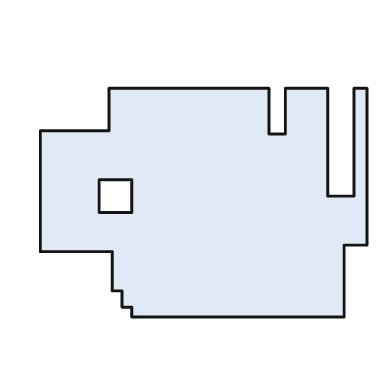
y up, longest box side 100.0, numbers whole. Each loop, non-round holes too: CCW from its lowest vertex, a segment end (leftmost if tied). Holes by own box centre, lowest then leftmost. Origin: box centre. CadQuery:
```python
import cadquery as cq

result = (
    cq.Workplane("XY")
    .moveTo(-22.0, -35.0)
    .lineTo(43.0, -35.0)
    .lineTo(43.0, -13.0)
    .lineTo(50.0, -13.0)
    .lineTo(50.0, 35.0)
    .lineTo(46.0, 35.0)
    .lineTo(46.0, 2.0)
    .lineTo(38.0, 2.0)
    .lineTo(38.0, 35.0)
    .lineTo(25.0, 35.0)
    .lineTo(25.0, 21.0)
    .lineTo(20.0, 21.0)
    .lineTo(20.0, 35.0)
    .lineTo(-29.0, 35.0)
    .lineTo(-29.0, 22.0)
    .lineTo(-50.0, 22.0)
    .lineTo(-50.0, -15.0)
    .lineTo(-28.0, -15.0)
    .lineTo(-28.0, -27.0)
    .lineTo(-25.0, -27.0)
    .lineTo(-25.0, -32.0)
    .lineTo(-22.0, -32.0)
    .close()
    .moveTo(-32.0, -3.0)
    .lineTo(-22.0, -3.0)
    .lineTo(-22.0, 7.0)
    .lineTo(-32.0, 7.0)
    .close()
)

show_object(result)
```